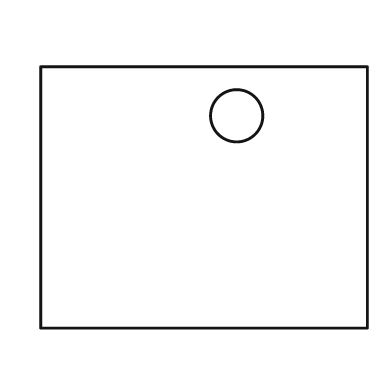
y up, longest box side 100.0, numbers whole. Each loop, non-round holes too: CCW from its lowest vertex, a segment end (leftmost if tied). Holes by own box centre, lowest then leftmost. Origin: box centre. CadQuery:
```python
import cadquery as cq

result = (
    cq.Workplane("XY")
    .moveTo(-50.0, -40.0)
    .lineTo(50.0, -40.0)
    .lineTo(50.0, 40.0)
    .lineTo(-50.0, 40.0)
    .close()
    .moveTo(10.0, 25.0)
    .circle(8.0)
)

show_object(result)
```